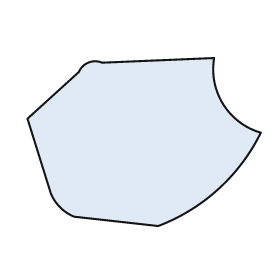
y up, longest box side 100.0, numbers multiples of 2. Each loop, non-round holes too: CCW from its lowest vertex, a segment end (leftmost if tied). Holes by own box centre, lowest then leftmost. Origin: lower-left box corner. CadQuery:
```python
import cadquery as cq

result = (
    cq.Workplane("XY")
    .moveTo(56.0, 0.0)
    .threePointArc((82.0, 16.0), (100.0, 40.0))
    .threePointArc((84.0, 52.0), (80.0, 72.0))
    .lineTo(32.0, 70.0)
    .threePointArc((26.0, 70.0), (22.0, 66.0))
    .lineTo(0.0, 46.0)
    .lineTo(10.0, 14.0)
    .threePointArc((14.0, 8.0), (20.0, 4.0))
    .close()
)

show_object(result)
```